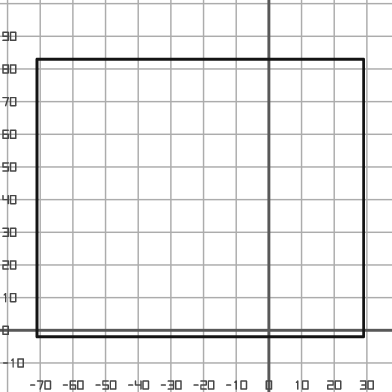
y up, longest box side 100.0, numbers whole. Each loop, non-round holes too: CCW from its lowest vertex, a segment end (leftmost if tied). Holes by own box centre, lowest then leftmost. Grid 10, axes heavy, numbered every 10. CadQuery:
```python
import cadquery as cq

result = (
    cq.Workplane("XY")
    .moveTo(-71.0, -2.0)
    .lineTo(29.0, -2.0)
    .lineTo(29.0, 83.0)
    .lineTo(-71.0, 83.0)
    .close()
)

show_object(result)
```